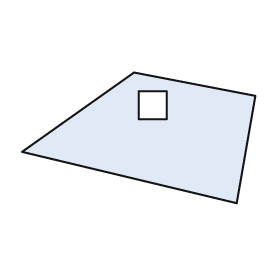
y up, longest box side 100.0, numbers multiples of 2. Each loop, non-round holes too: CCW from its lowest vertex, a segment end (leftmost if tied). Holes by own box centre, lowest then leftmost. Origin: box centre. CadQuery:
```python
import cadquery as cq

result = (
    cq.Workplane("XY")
    .moveTo(42.0, -28.0)
    .lineTo(50.0, 18.0)
    .lineTo(-2.0, 28.0)
    .lineTo(-50.0, -6.0)
    .close()
    .moveTo(0.0, 8.0)
    .lineTo(12.0, 8.0)
    .lineTo(12.0, 20.0)
    .lineTo(0.0, 20.0)
    .close()
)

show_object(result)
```